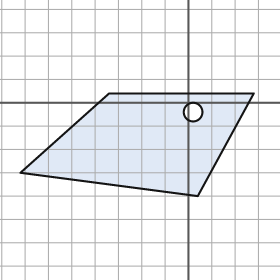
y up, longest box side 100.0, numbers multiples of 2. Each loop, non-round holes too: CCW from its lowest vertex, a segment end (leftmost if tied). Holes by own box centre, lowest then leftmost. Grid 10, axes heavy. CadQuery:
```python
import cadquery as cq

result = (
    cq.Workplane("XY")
    .moveTo(4.0, -40.0)
    .lineTo(28.0, 4.0)
    .lineTo(-34.0, 4.0)
    .lineTo(-72.0, -30.0)
    .close()
    .moveTo(2.0, -4.0)
    .circle(4.0)
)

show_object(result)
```